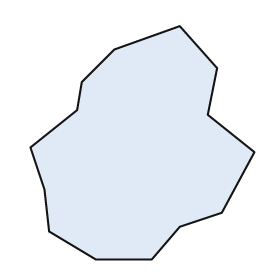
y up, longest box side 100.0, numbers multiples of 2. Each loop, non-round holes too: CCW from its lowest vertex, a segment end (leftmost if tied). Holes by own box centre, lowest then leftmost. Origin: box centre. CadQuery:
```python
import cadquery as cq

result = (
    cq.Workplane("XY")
    .moveTo(-20.0, -50.0)
    .lineTo(4.0, -50.0)
    .lineTo(16.0, -36.0)
    .lineTo(34.0, -30.0)
    .lineTo(48.0, -4.0)
    .lineTo(28.0, 12.0)
    .lineTo(32.0, 32.0)
    .lineTo(16.0, 50.0)
    .lineTo(-12.0, 40.0)
    .lineTo(-26.0, 26.0)
    .lineTo(-28.0, 14.0)
    .lineTo(-48.0, -2.0)
    .lineTo(-42.0, -20.0)
    .lineTo(-40.0, -38.0)
    .close()
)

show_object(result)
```